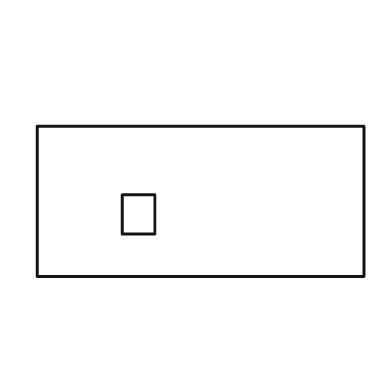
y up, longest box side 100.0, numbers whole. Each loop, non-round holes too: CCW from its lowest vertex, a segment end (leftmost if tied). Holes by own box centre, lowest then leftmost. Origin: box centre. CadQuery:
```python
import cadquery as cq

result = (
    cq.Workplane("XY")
    .moveTo(-50.0, -23.0)
    .lineTo(50.0, -23.0)
    .lineTo(50.0, 23.0)
    .lineTo(-50.0, 23.0)
    .close()
    .moveTo(-24.0, -10.0)
    .lineTo(-14.0, -10.0)
    .lineTo(-14.0, 2.0)
    .lineTo(-24.0, 2.0)
    .close()
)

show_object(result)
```